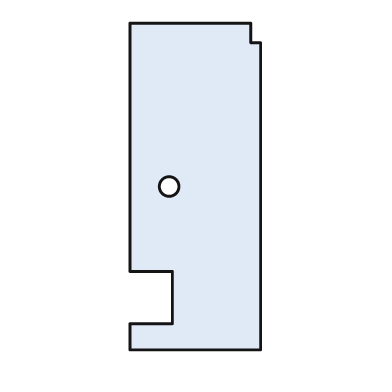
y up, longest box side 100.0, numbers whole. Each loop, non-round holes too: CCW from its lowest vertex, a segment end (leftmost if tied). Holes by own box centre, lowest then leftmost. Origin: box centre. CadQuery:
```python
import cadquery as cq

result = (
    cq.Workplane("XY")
    .moveTo(-20.0, -50.0)
    .lineTo(20.0, -50.0)
    .lineTo(20.0, 44.0)
    .lineTo(17.0, 44.0)
    .lineTo(17.0, 50.0)
    .lineTo(-20.0, 50.0)
    .lineTo(-20.0, -26.0)
    .lineTo(-7.0, -26.0)
    .lineTo(-7.0, -42.0)
    .lineTo(-20.0, -42.0)
    .close()
    .moveTo(-8.0, 0.0)
    .circle(3.0)
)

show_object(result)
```